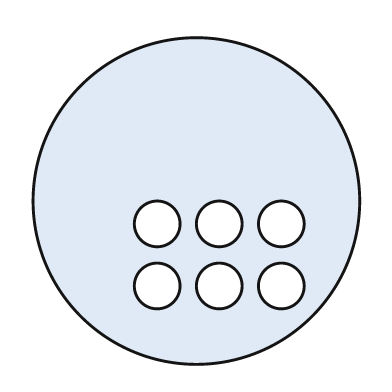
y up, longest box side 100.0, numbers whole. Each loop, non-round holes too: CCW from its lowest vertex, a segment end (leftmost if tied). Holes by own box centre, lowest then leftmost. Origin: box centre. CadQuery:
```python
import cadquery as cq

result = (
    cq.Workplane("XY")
    .moveTo(0.0, 0.0)
    .circle(50.0)
    .moveTo(-12.0, -26.0)
    .circle(7.0)
    .moveTo(7.0, -26.0)
    .circle(7.0)
    .moveTo(26.0, -26.0)
    .circle(7.0)
    .moveTo(-12.0, -7.0)
    .circle(7.0)
    .moveTo(7.0, -7.0)
    .circle(7.0)
    .moveTo(26.0, -7.0)
    .circle(7.0)
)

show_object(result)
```